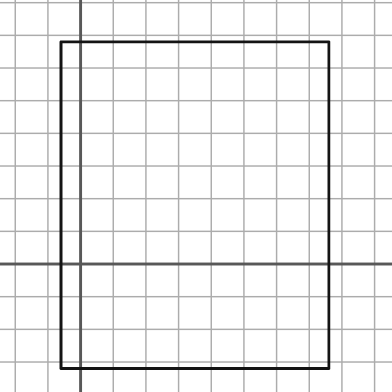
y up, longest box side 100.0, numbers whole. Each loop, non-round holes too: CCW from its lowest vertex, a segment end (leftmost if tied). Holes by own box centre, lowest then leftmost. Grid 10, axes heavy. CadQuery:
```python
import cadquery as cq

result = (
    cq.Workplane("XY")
    .moveTo(-6.0, -32.0)
    .lineTo(76.0, -32.0)
    .lineTo(76.0, 68.0)
    .lineTo(-6.0, 68.0)
    .close()
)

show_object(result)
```